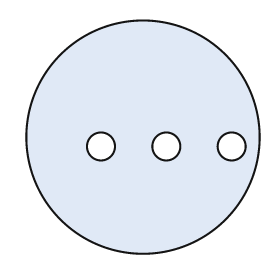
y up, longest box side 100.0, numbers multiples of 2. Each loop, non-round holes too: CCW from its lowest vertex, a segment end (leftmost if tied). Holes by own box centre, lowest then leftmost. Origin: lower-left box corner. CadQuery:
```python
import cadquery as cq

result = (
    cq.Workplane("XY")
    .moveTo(50.0, 50.0)
    .circle(50.0)
    .moveTo(32.0, 46.0)
    .circle(6.0)
    .moveTo(60.0, 46.0)
    .circle(6.0)
    .moveTo(88.0, 46.0)
    .circle(6.0)
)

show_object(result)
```